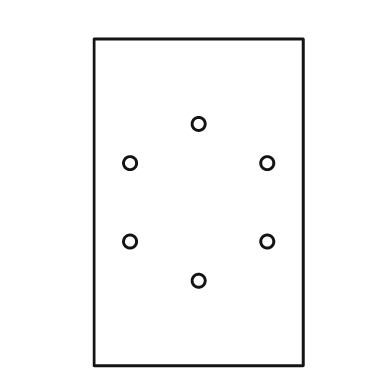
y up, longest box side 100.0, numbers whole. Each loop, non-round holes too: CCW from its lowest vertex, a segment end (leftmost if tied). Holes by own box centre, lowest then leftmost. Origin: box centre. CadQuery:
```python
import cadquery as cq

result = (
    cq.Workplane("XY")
    .moveTo(-32.0, -50.0)
    .lineTo(32.0, -50.0)
    .lineTo(32.0, 50.0)
    .lineTo(-32.0, 50.0)
    .close()
    .moveTo(0.0, -24.0)
    .circle(2.0)
    .moveTo(-21.0, -12.0)
    .circle(2.0)
    .moveTo(21.0, -12.0)
    .circle(2.0)
    .moveTo(-21.0, 12.0)
    .circle(2.0)
    .moveTo(21.0, 12.0)
    .circle(2.0)
    .moveTo(0.0, 24.0)
    .circle(2.0)
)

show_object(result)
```